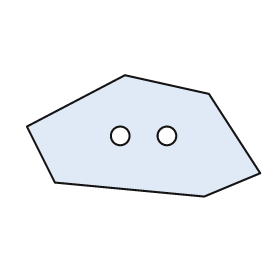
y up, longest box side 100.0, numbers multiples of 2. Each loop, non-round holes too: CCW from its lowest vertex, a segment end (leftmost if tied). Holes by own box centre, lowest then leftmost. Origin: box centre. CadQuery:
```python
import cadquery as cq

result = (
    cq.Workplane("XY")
    .moveTo(26.0, -26.0)
    .lineTo(50.0, -16.0)
    .lineTo(28.0, 18.0)
    .lineTo(-8.0, 26.0)
    .lineTo(-50.0, 4.0)
    .lineTo(-38.0, -20.0)
    .close()
    .moveTo(-10.0, 0.0)
    .circle(4.0)
    .moveTo(10.0, 0.0)
    .circle(4.0)
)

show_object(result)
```